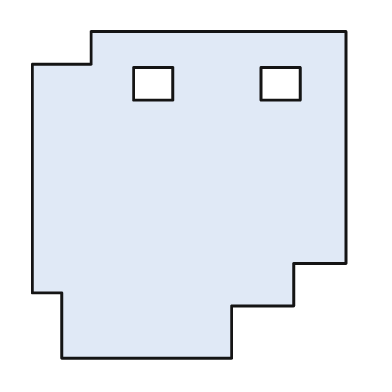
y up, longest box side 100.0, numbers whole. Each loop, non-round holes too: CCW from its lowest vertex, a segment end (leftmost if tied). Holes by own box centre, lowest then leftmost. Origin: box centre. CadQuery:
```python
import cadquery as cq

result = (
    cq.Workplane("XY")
    .moveTo(-39.0, -50.0)
    .lineTo(13.0, -50.0)
    .lineTo(13.0, -34.0)
    .lineTo(32.0, -34.0)
    .lineTo(32.0, -21.0)
    .lineTo(48.0, -21.0)
    .lineTo(48.0, 50.0)
    .lineTo(-30.0, 50.0)
    .lineTo(-30.0, 40.0)
    .lineTo(-48.0, 40.0)
    .lineTo(-48.0, -30.0)
    .lineTo(-39.0, -30.0)
    .close()
    .moveTo(-17.0, 29.0)
    .lineTo(-5.0, 29.0)
    .lineTo(-5.0, 39.0)
    .lineTo(-17.0, 39.0)
    .close()
    .moveTo(22.0, 29.0)
    .lineTo(34.0, 29.0)
    .lineTo(34.0, 39.0)
    .lineTo(22.0, 39.0)
    .close()
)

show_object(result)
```